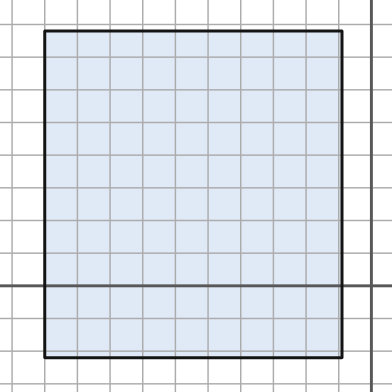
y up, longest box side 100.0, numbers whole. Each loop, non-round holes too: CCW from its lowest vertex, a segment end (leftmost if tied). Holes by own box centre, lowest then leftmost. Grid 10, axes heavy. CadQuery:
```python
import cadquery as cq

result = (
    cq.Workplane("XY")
    .moveTo(-100.0, -22.0)
    .lineTo(-9.0, -22.0)
    .lineTo(-9.0, 78.0)
    .lineTo(-100.0, 78.0)
    .close()
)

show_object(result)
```